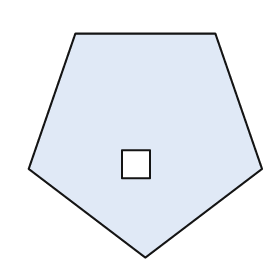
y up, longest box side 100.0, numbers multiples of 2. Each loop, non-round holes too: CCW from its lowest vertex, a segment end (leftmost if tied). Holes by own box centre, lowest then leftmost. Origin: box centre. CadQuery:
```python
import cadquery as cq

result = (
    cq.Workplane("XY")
    .moveTo(0.0, -48.0)
    .lineTo(50.0, -10.0)
    .lineTo(30.0, 48.0)
    .lineTo(-30.0, 48.0)
    .lineTo(-50.0, -10.0)
    .close()
    .moveTo(-10.0, -14.0)
    .lineTo(2.0, -14.0)
    .lineTo(2.0, -2.0)
    .lineTo(-10.0, -2.0)
    .close()
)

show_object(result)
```